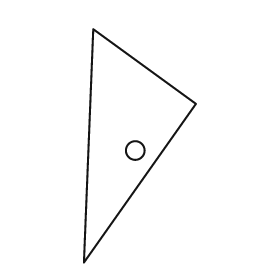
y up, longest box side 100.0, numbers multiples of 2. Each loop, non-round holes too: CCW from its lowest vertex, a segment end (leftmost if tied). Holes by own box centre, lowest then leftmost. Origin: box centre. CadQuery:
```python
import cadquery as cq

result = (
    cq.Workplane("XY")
    .moveTo(-24.0, -50.0)
    .lineTo(24.0, 18.0)
    .lineTo(-20.0, 50.0)
    .close()
    .moveTo(-2.0, -2.0)
    .circle(4.0)
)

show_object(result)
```